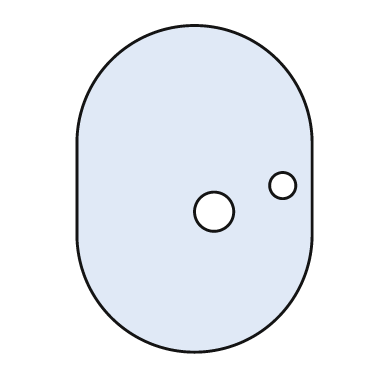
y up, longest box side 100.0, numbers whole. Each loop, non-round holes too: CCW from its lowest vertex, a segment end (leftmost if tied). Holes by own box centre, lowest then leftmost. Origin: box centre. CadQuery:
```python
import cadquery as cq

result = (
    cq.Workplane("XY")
    .moveTo(-36.0, -14.0)
    .threePointArc((0.0, -50.0), (36.0, -14.0))
    .lineTo(36.0, 14.0)
    .threePointArc((0.0, 50.0), (-36.0, 14.0))
    .close()
    .moveTo(6.0, -7.0)
    .circle(6.0)
    .moveTo(27.0, 1.0)
    .circle(4.0)
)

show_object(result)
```